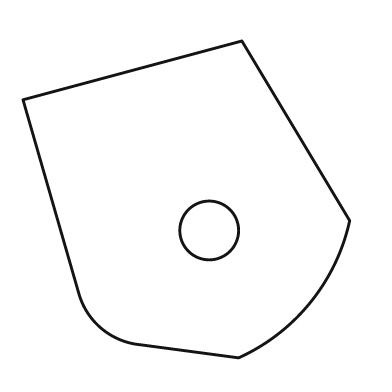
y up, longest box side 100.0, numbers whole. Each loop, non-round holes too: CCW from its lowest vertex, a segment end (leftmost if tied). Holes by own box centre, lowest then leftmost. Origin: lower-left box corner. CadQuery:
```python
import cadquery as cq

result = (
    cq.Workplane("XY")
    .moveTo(66.0, 0.0)
    .threePointArc((88.0, 17.0), (100.0, 42.0))
    .lineTo(67.0, 97.0)
    .lineTo(0.0, 79.0)
    .lineTo(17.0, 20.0)
    .threePointArc((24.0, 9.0), (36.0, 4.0))
    .close()
    .moveTo(57.0, 39.0)
    .circle(9.0)
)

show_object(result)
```